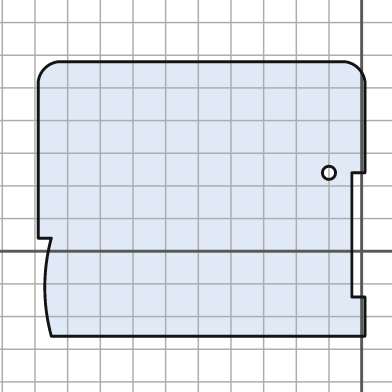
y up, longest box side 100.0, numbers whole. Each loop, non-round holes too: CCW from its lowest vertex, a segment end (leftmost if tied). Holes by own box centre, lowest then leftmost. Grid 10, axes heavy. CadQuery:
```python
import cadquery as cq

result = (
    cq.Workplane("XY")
    .moveTo(-95.0, -26.0)
    .lineTo(1.0, -26.0)
    .lineTo(1.0, -14.0)
    .lineTo(-3.0, -14.0)
    .lineTo(-3.0, 24.0)
    .lineTo(1.0, 24.0)
    .lineTo(1.0, 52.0)
    .threePointArc((-1.0, 56.0), (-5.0, 58.0))
    .lineTo(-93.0, 58.0)
    .threePointArc((-97.0, 56.0), (-99.0, 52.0))
    .lineTo(-99.0, 4.0)
    .lineTo(-95.0, 4.0)
    .threePointArc((-97.0, -11.0), (-95.0, -26.0))
    .close()
    .moveTo(-10.0, 24.0)
    .circle(2.0)
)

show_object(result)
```